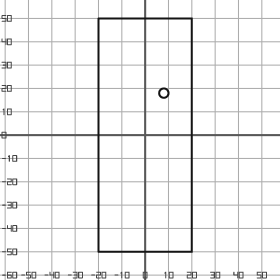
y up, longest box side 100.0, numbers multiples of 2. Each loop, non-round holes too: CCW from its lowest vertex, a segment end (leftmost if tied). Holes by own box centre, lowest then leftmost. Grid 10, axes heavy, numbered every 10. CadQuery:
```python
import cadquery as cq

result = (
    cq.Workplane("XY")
    .moveTo(-20.0, -50.0)
    .lineTo(20.0, -50.0)
    .lineTo(20.0, 50.0)
    .lineTo(-20.0, 50.0)
    .close()
    .moveTo(8.0, 18.0)
    .circle(2.0)
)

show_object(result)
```